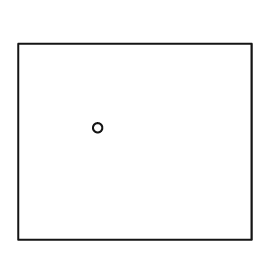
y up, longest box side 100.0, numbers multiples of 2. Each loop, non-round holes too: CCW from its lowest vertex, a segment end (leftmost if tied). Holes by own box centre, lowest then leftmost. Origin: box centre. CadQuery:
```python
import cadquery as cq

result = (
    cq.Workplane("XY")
    .moveTo(-50.0, -42.0)
    .lineTo(50.0, -42.0)
    .lineTo(50.0, 42.0)
    .lineTo(-50.0, 42.0)
    .close()
    .moveTo(-16.0, 6.0)
    .circle(2.0)
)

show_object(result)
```